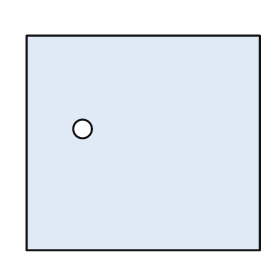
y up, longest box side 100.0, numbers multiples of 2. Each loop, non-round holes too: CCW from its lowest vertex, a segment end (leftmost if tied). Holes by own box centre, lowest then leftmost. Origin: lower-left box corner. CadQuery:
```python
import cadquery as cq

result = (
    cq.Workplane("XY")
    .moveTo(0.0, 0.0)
    .lineTo(100.0, 0.0)
    .lineTo(100.0, 92.0)
    .lineTo(0.0, 92.0)
    .close()
    .moveTo(24.0, 52.0)
    .circle(4.0)
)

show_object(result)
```